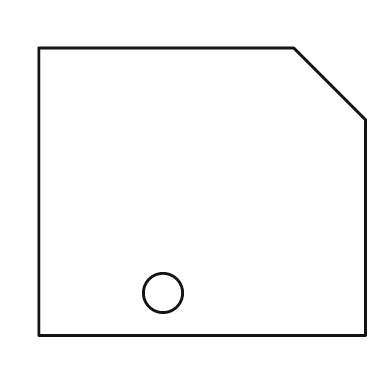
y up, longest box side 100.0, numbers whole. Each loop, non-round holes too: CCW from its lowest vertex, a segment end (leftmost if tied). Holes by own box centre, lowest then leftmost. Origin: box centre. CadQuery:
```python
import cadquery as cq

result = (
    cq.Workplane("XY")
    .moveTo(-50.0, -44.0)
    .lineTo(50.0, -44.0)
    .lineTo(50.0, 22.0)
    .lineTo(28.0, 44.0)
    .lineTo(-50.0, 44.0)
    .close()
    .moveTo(-12.0, -31.0)
    .circle(6.0)
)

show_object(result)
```